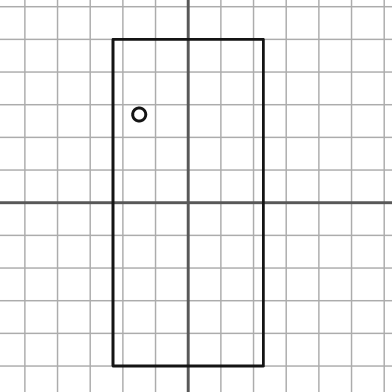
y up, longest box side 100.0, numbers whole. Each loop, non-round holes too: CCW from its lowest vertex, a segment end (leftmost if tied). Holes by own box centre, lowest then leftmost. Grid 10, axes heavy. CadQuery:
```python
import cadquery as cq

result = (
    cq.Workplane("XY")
    .moveTo(-23.0, -50.0)
    .lineTo(23.0, -50.0)
    .lineTo(23.0, 50.0)
    .lineTo(-23.0, 50.0)
    .close()
    .moveTo(-15.0, 27.0)
    .circle(2.0)
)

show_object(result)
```